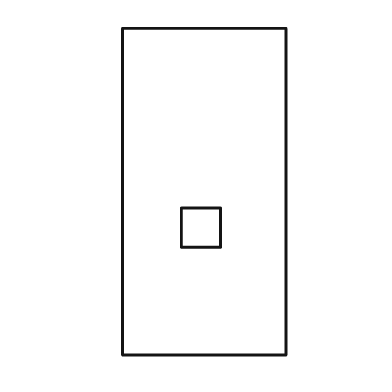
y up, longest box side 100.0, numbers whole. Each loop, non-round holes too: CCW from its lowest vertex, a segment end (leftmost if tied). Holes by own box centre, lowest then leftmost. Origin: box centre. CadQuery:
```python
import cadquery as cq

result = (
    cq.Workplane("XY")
    .moveTo(-25.0, -50.0)
    .lineTo(25.0, -50.0)
    .lineTo(25.0, 50.0)
    .lineTo(-25.0, 50.0)
    .close()
    .moveTo(-7.0, -17.0)
    .lineTo(5.0, -17.0)
    .lineTo(5.0, -5.0)
    .lineTo(-7.0, -5.0)
    .close()
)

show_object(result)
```